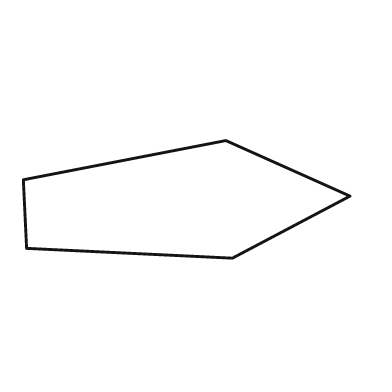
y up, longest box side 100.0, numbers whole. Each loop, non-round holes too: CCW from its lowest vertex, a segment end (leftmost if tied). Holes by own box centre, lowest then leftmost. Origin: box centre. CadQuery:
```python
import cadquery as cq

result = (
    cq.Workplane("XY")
    .moveTo(14.0, -18.0)
    .lineTo(50.0, 1.0)
    .lineTo(12.0, 18.0)
    .lineTo(-50.0, 6.0)
    .lineTo(-49.0, -15.0)
    .close()
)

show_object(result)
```